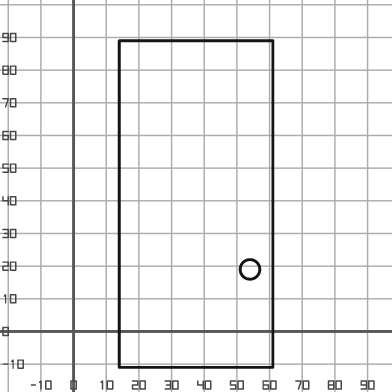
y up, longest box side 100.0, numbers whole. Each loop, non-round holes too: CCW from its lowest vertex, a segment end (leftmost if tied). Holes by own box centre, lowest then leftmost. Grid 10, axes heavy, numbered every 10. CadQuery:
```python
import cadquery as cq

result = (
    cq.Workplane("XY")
    .moveTo(14.0, -11.0)
    .lineTo(61.0, -11.0)
    .lineTo(61.0, 89.0)
    .lineTo(14.0, 89.0)
    .close()
    .moveTo(54.0, 19.0)
    .circle(3.0)
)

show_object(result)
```